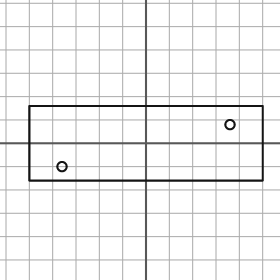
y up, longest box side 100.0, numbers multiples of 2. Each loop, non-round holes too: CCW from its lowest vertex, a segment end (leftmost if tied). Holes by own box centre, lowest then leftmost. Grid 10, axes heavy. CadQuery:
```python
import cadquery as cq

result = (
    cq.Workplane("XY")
    .moveTo(-50.0, -16.0)
    .lineTo(50.0, -16.0)
    .lineTo(50.0, 16.0)
    .lineTo(-50.0, 16.0)
    .close()
    .moveTo(-36.0, -10.0)
    .circle(2.0)
    .moveTo(36.0, 8.0)
    .circle(2.0)
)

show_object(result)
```